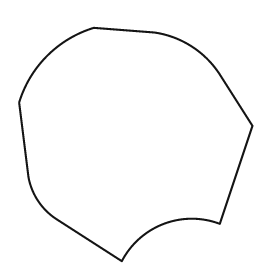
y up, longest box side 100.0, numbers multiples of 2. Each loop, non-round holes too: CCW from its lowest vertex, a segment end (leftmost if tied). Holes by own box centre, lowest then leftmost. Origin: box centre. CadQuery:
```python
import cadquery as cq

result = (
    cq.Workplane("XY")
    .moveTo(-6.0, -50.0)
    .threePointArc((12.0, -34.0), (36.0, -34.0))
    .lineTo(50.0, 8.0)
    .lineTo(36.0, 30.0)
    .threePointArc((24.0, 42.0), (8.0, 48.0))
    .lineTo(-18.0, 50.0)
    .threePointArc((-38.0, 38.0), (-50.0, 18.0))
    .lineTo(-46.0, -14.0)
    .threePointArc((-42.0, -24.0), (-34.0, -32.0))
    .close()
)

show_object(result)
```